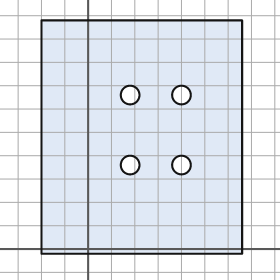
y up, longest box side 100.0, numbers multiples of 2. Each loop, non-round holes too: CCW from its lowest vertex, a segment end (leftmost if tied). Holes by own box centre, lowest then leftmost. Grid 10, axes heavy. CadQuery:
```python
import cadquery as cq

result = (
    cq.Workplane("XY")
    .moveTo(-20.0, -2.0)
    .lineTo(66.0, -2.0)
    .lineTo(66.0, 98.0)
    .lineTo(-20.0, 98.0)
    .close()
    .moveTo(18.0, 36.0)
    .circle(4.0)
    .moveTo(40.0, 36.0)
    .circle(4.0)
    .moveTo(18.0, 66.0)
    .circle(4.0)
    .moveTo(40.0, 66.0)
    .circle(4.0)
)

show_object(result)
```